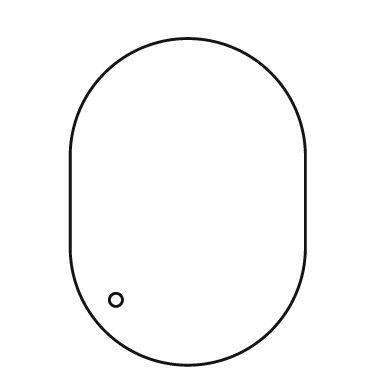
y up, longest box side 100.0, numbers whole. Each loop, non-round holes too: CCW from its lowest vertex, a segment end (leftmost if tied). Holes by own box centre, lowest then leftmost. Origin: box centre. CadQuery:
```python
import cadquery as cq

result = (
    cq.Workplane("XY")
    .moveTo(-36.0, -14.0)
    .threePointArc((0.0, -50.0), (36.0, -14.0))
    .lineTo(36.0, 14.0)
    .threePointArc((0.0, 50.0), (-36.0, 14.0))
    .close()
    .moveTo(-22.0, -30.0)
    .circle(2.0)
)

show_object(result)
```